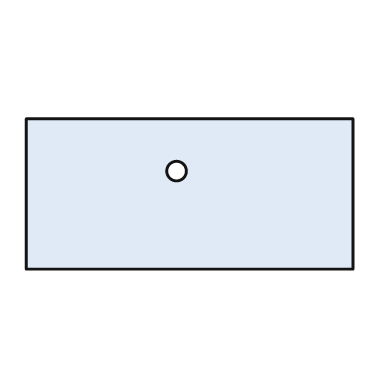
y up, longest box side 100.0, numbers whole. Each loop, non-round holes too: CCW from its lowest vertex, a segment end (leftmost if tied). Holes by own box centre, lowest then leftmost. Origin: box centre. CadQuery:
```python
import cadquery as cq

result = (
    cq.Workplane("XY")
    .moveTo(-50.0, -23.0)
    .lineTo(50.0, -23.0)
    .lineTo(50.0, 23.0)
    .lineTo(-50.0, 23.0)
    .close()
    .moveTo(-4.0, 7.0)
    .circle(3.0)
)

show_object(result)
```